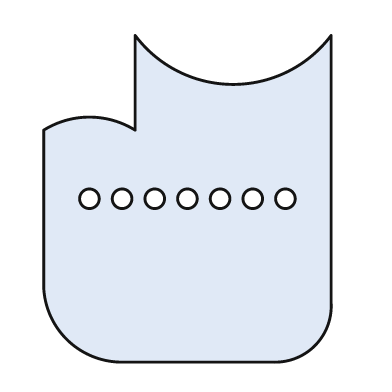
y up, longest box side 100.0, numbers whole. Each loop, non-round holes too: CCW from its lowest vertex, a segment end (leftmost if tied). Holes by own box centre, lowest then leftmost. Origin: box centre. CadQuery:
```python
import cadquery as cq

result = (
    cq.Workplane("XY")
    .moveTo(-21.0, -50.0)
    .lineTo(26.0, -50.0)
    .threePointArc((39.0, -45.0), (44.0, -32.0))
    .lineTo(44.0, 50.0)
    .threePointArc((14.0, 35.0), (-16.0, 50.0))
    .lineTo(-16.0, 21.0)
    .threePointArc((-30.0, 25.0), (-44.0, 21.0))
    .lineTo(-44.0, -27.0)
    .threePointArc((-37.0, -43.0), (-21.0, -50.0))
    .close()
    .moveTo(-30.0, 0.0)
    .circle(3.0)
    .moveTo(-20.0, 0.0)
    .circle(3.0)
    .moveTo(-10.0, 0.0)
    .circle(3.0)
    .moveTo(0.0, 0.0)
    .circle(3.0)
    .moveTo(10.0, 0.0)
    .circle(3.0)
    .moveTo(20.0, 0.0)
    .circle(3.0)
    .moveTo(30.0, 0.0)
    .circle(3.0)
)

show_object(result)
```